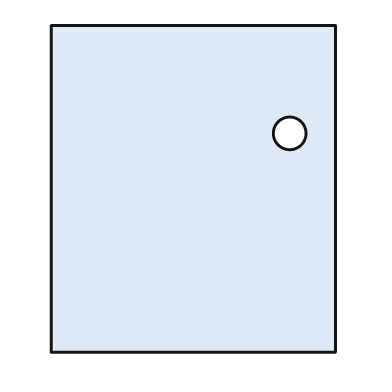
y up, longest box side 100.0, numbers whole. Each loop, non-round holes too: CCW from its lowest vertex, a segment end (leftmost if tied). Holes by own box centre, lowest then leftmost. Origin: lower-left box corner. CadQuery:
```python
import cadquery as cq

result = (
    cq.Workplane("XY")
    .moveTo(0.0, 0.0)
    .lineTo(87.0, 0.0)
    .lineTo(87.0, 100.0)
    .lineTo(0.0, 100.0)
    .close()
    .moveTo(73.0, 67.0)
    .circle(5.0)
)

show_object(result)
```